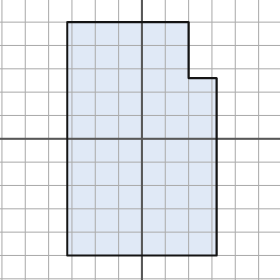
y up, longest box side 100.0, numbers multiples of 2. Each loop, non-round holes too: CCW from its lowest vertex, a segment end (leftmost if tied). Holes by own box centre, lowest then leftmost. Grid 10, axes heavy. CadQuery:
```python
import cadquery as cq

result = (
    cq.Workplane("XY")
    .moveTo(-32.0, -50.0)
    .lineTo(32.0, -50.0)
    .lineTo(32.0, 26.0)
    .lineTo(20.0, 26.0)
    .lineTo(20.0, 50.0)
    .lineTo(-32.0, 50.0)
    .close()
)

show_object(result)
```